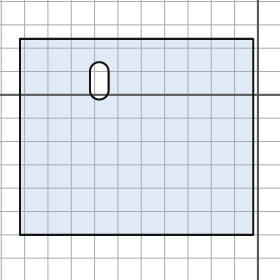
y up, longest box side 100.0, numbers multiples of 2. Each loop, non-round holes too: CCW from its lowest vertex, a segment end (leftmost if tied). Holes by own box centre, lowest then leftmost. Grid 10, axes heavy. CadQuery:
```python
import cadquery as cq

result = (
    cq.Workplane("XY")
    .moveTo(-102.0, -60.0)
    .lineTo(-2.0, -60.0)
    .lineTo(-2.0, 24.0)
    .lineTo(-102.0, 24.0)
    .close()
    .moveTo(-72.0, 2.0)
    .threePointArc((-68.0, -2.0), (-64.0, 2.0))
    .lineTo(-64.0, 10.0)
    .threePointArc((-68.0, 14.0), (-72.0, 10.0))
    .close()
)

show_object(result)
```